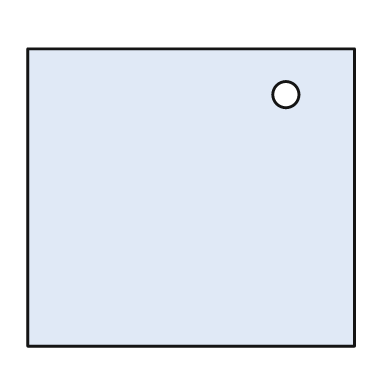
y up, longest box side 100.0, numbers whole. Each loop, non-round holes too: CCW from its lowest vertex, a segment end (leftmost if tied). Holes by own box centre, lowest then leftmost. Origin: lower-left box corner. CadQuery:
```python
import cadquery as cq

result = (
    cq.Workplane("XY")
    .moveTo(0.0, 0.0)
    .lineTo(100.0, 0.0)
    .lineTo(100.0, 91.0)
    .lineTo(0.0, 91.0)
    .close()
    .moveTo(79.0, 77.0)
    .circle(4.0)
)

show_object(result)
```